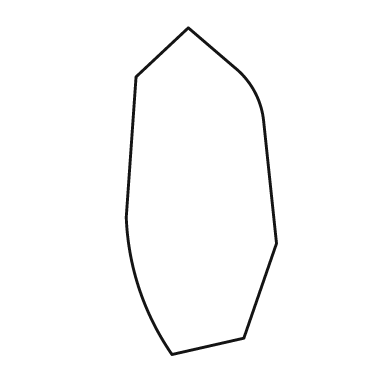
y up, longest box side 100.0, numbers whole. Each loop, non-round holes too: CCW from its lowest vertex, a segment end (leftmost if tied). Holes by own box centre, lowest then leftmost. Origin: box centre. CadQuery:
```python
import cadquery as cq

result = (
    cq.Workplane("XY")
    .moveTo(-9.0, -50.0)
    .lineTo(13.0, -45.0)
    .lineTo(23.0, -16.0)
    .lineTo(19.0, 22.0)
    .threePointArc((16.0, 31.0), (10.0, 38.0))
    .lineTo(-4.0, 50.0)
    .lineTo(-20.0, 35.0)
    .lineTo(-23.0, -8.0)
    .threePointArc((-19.0, -30.0), (-9.0, -50.0))
    .close()
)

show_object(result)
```